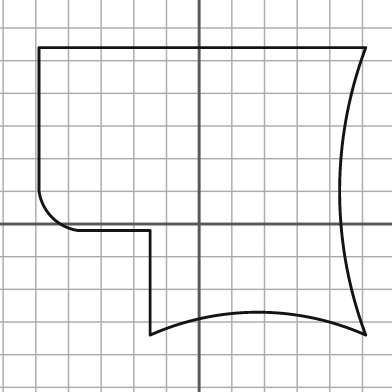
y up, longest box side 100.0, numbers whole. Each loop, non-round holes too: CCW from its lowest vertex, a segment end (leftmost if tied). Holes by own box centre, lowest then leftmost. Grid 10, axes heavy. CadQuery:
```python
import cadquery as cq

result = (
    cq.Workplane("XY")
    .moveTo(-15.0, -34.0)
    .threePointArc((18.0, -27.0), (51.0, -34.0))
    .threePointArc((43.0, 10.0), (51.0, 54.0))
    .lineTo(-49.0, 54.0)
    .lineTo(-49.0, 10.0)
    .threePointArc((-45.0, 2.0), (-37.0, -2.0))
    .lineTo(-15.0, -2.0)
    .close()
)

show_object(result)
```